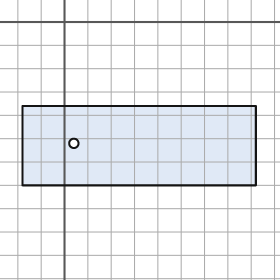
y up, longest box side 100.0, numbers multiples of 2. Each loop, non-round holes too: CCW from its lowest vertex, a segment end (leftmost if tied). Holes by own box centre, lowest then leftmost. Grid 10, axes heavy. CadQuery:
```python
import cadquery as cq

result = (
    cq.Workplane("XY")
    .moveTo(-18.0, -70.0)
    .lineTo(82.0, -70.0)
    .lineTo(82.0, -36.0)
    .lineTo(-18.0, -36.0)
    .close()
    .moveTo(4.0, -52.0)
    .circle(2.0)
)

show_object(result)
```